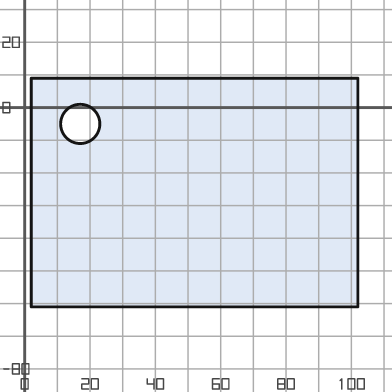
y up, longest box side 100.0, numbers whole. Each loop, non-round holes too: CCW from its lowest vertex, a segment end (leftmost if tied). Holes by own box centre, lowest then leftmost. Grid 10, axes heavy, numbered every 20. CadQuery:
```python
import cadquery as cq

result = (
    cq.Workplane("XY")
    .moveTo(2.0, -61.0)
    .lineTo(102.0, -61.0)
    .lineTo(102.0, 9.0)
    .lineTo(2.0, 9.0)
    .close()
    .moveTo(17.0, -5.0)
    .circle(6.0)
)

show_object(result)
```